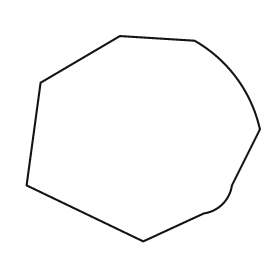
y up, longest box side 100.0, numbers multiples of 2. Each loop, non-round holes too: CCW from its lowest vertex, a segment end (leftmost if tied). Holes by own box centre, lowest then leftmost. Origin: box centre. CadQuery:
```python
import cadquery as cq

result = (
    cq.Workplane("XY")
    .moveTo(0.0, -44.0)
    .lineTo(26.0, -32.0)
    .threePointArc((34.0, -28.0), (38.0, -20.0))
    .lineTo(50.0, 4.0)
    .threePointArc((40.0, 26.0), (22.0, 42.0))
    .lineTo(-10.0, 44.0)
    .lineTo(-44.0, 24.0)
    .lineTo(-50.0, -20.0)
    .close()
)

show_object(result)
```